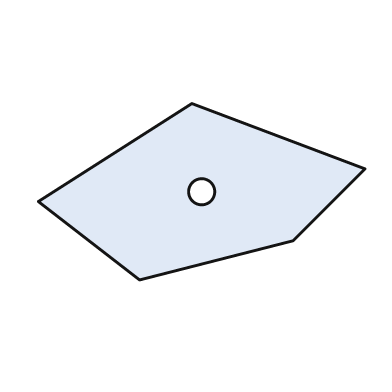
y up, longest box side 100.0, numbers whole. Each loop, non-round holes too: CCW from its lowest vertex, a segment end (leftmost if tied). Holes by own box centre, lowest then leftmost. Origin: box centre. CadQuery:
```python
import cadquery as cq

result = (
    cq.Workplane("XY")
    .moveTo(-19.0, -27.0)
    .lineTo(28.0, -15.0)
    .lineTo(50.0, 7.0)
    .lineTo(-3.0, 27.0)
    .lineTo(-50.0, -3.0)
    .close()
    .moveTo(0.0, 0.0)
    .circle(4.0)
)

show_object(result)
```